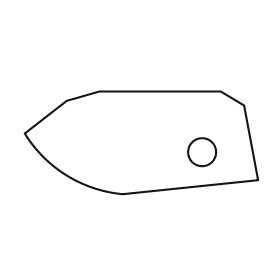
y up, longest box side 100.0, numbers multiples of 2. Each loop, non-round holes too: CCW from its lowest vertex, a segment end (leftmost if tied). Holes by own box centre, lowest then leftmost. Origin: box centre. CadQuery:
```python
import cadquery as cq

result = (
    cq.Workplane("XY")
    .moveTo(-8.0, -22.0)
    .lineTo(50.0, -16.0)
    .lineTo(44.0, 16.0)
    .lineTo(34.0, 22.0)
    .lineTo(-18.0, 22.0)
    .lineTo(-32.0, 18.0)
    .lineTo(-50.0, 4.0)
    .threePointArc((-32.0, -14.0), (-8.0, -22.0))
    .close()
    .moveTo(26.0, -4.0)
    .circle(6.0)
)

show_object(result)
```